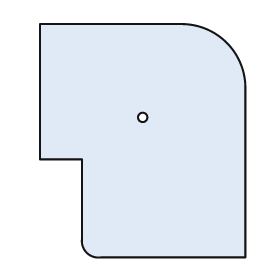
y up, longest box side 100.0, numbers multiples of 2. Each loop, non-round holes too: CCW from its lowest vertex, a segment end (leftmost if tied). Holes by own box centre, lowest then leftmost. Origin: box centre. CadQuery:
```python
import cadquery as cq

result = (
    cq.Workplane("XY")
    .moveTo(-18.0, -50.0)
    .lineTo(44.0, -50.0)
    .lineTo(44.0, 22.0)
    .threePointArc((36.0, 42.0), (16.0, 50.0))
    .lineTo(-44.0, 50.0)
    .lineTo(-44.0, -8.0)
    .lineTo(-26.0, -8.0)
    .lineTo(-26.0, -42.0)
    .threePointArc((-24.0, -48.0), (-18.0, -50.0))
    .close()
    .moveTo(0.0, 10.0)
    .circle(2.0)
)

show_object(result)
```